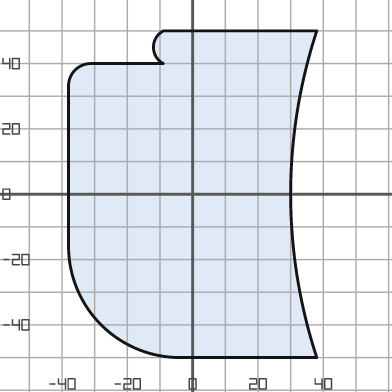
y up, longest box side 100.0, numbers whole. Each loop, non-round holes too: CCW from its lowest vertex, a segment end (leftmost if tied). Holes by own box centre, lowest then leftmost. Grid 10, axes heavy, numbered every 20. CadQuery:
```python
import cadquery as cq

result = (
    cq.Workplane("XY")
    .moveTo(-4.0, -50.0)
    .lineTo(38.0, -50.0)
    .threePointArc((30.0, 0.0), (38.0, 50.0))
    .lineTo(-9.0, 50.0)
    .threePointArc((-12.0, 45.0), (-9.0, 40.0))
    .lineTo(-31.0, 40.0)
    .threePointArc((-36.0, 38.0), (-38.0, 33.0))
    .lineTo(-38.0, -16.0)
    .threePointArc((-28.0, -40.0), (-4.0, -50.0))
    .close()
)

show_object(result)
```